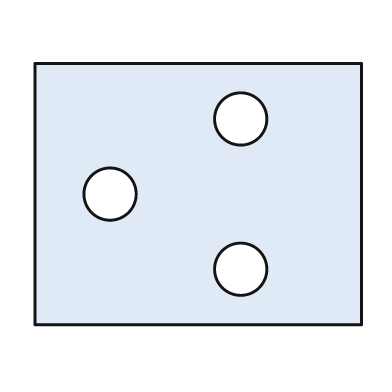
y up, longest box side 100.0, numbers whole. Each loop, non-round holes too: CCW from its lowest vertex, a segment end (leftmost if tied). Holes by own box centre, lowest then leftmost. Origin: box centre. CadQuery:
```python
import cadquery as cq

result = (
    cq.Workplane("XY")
    .moveTo(-50.0, -40.0)
    .lineTo(50.0, -40.0)
    .lineTo(50.0, 40.0)
    .lineTo(-50.0, 40.0)
    .close()
    .moveTo(13.0, -23.0)
    .circle(8.0)
    .moveTo(-27.0, 0.0)
    .circle(8.0)
    .moveTo(13.0, 23.0)
    .circle(8.0)
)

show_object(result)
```